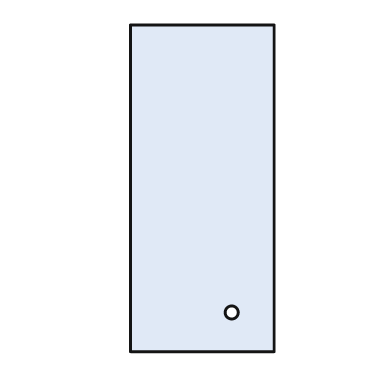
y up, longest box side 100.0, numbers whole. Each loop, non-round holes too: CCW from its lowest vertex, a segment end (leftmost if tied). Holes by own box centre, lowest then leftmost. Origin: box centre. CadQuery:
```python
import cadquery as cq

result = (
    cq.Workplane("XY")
    .moveTo(-22.0, -50.0)
    .lineTo(22.0, -50.0)
    .lineTo(22.0, 50.0)
    .lineTo(-22.0, 50.0)
    .close()
    .moveTo(9.0, -38.0)
    .circle(2.0)
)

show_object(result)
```